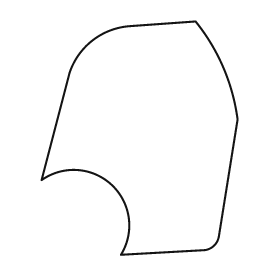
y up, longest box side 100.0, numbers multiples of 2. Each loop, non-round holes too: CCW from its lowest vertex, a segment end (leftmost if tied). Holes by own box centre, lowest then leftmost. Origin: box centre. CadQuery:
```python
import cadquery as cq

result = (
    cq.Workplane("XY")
    .moveTo(-8.0, -50.0)
    .lineTo(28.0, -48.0)
    .threePointArc((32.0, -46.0), (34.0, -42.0))
    .lineTo(42.0, 8.0)
    .threePointArc((36.0, 30.0), (24.0, 50.0))
    .lineTo(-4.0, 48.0)
    .threePointArc((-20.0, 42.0), (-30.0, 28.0))
    .lineTo(-42.0, -18.0)
    .threePointArc((-12.0, -20.0), (-8.0, -50.0))
    .close()
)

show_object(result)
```